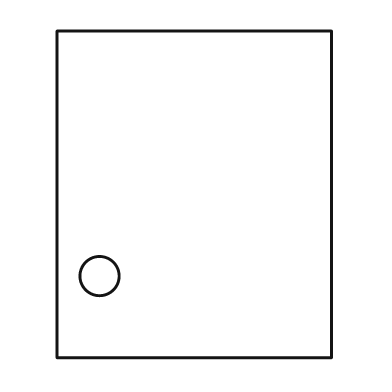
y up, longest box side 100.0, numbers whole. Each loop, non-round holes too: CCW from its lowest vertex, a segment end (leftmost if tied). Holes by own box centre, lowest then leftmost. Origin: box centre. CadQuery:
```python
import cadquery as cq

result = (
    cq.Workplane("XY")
    .moveTo(-42.0, -50.0)
    .lineTo(42.0, -50.0)
    .lineTo(42.0, 50.0)
    .lineTo(-42.0, 50.0)
    .close()
    .moveTo(-29.0, -25.0)
    .circle(6.0)
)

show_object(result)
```